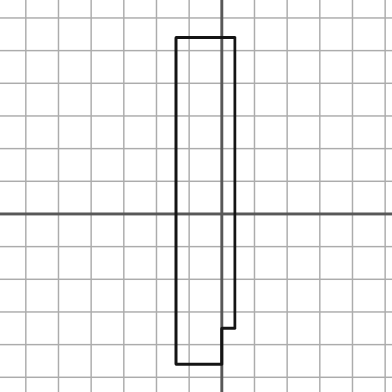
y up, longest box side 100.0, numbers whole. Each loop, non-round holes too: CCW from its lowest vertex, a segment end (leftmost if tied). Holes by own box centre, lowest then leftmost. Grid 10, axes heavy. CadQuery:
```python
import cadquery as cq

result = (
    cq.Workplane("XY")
    .moveTo(-14.0, -46.0)
    .lineTo(0.0, -46.0)
    .lineTo(0.0, -35.0)
    .lineTo(4.0, -35.0)
    .lineTo(4.0, 54.0)
    .lineTo(-14.0, 54.0)
    .close()
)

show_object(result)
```